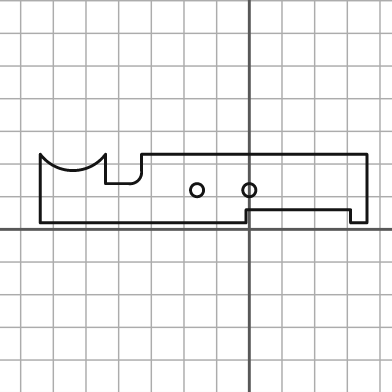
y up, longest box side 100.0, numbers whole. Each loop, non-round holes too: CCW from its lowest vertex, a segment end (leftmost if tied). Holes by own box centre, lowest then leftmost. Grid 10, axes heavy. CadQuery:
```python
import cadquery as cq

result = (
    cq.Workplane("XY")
    .moveTo(-64.0, 2.0)
    .lineTo(-1.0, 2.0)
    .lineTo(-1.0, 6.0)
    .lineTo(31.0, 6.0)
    .lineTo(31.0, 2.0)
    .lineTo(36.0, 2.0)
    .lineTo(36.0, 23.0)
    .lineTo(-33.0, 23.0)
    .lineTo(-33.0, 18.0)
    .threePointArc((-34.0, 15.0), (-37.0, 14.0))
    .lineTo(-44.0, 14.0)
    .lineTo(-44.0, 23.0)
    .threePointArc((-54.0, 18.0), (-64.0, 23.0))
    .close()
    .moveTo(-16.0, 12.0)
    .circle(2.0)
    .moveTo(0.0, 12.0)
    .circle(2.0)
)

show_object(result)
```